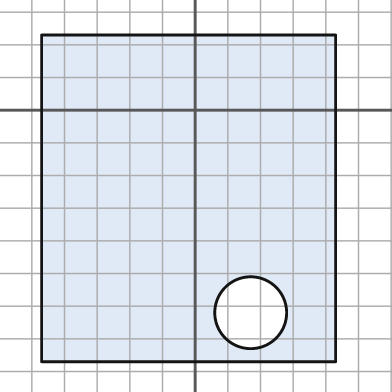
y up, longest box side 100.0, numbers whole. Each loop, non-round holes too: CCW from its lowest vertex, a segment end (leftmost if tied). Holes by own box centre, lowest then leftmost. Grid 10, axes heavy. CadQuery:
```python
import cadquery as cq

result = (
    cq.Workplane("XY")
    .moveTo(-47.0, -77.0)
    .lineTo(43.0, -77.0)
    .lineTo(43.0, 23.0)
    .lineTo(-47.0, 23.0)
    .close()
    .moveTo(17.0, -62.0)
    .circle(11.0)
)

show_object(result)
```